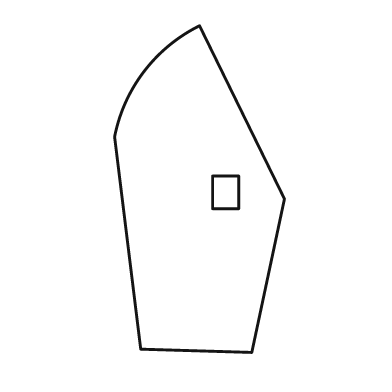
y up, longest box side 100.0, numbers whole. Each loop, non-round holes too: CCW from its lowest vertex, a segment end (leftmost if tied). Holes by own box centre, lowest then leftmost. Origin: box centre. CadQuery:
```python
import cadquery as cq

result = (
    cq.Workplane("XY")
    .moveTo(16.0, -50.0)
    .lineTo(26.0, -3.0)
    .lineTo(0.0, 50.0)
    .threePointArc((-17.0, 36.0), (-26.0, 16.0))
    .lineTo(-18.0, -49.0)
    .close()
    .moveTo(4.0, -6.0)
    .lineTo(12.0, -6.0)
    .lineTo(12.0, 4.0)
    .lineTo(4.0, 4.0)
    .close()
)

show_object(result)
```